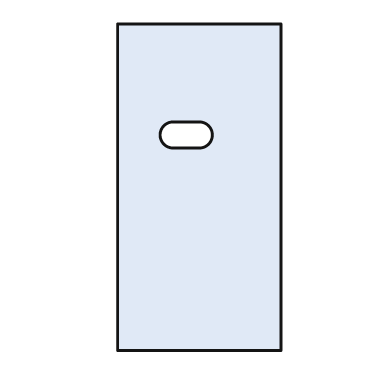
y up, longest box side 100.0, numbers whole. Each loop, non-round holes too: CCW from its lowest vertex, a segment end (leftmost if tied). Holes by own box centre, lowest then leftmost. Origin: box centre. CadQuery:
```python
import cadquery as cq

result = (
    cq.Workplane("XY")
    .moveTo(-25.0, -50.0)
    .lineTo(25.0, -50.0)
    .lineTo(25.0, 50.0)
    .lineTo(-25.0, 50.0)
    .close()
    .moveTo(-8.0, 12.0)
    .lineTo(0.0, 12.0)
    .threePointArc((4.0, 16.0), (0.0, 20.0))
    .lineTo(-8.0, 20.0)
    .threePointArc((-12.0, 16.0), (-8.0, 12.0))
    .close()
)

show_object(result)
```